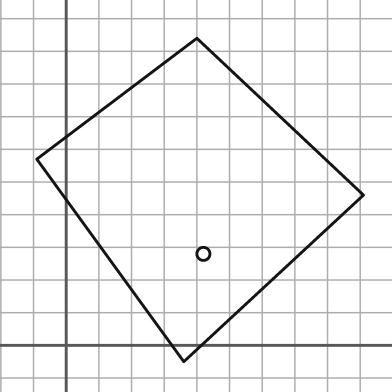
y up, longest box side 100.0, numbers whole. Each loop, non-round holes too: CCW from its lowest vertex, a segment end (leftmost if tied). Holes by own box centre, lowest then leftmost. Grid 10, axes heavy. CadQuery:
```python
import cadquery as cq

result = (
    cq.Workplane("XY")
    .moveTo(36.0, -5.0)
    .lineTo(91.0, 46.0)
    .lineTo(40.0, 94.0)
    .lineTo(-9.0, 57.0)
    .close()
    .moveTo(42.0, 28.0)
    .circle(2.0)
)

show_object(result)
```